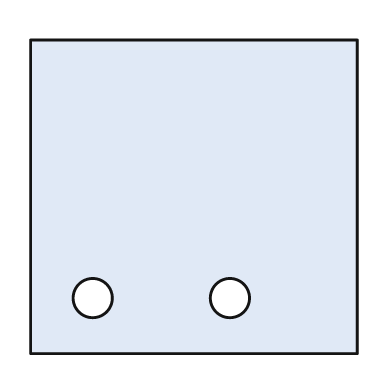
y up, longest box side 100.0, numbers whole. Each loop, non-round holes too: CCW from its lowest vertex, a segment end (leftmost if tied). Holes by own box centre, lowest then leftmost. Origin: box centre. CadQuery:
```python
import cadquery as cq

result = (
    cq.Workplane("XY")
    .moveTo(-50.0, -48.0)
    .lineTo(50.0, -48.0)
    .lineTo(50.0, 48.0)
    .lineTo(-50.0, 48.0)
    .close()
    .moveTo(-31.0, -31.0)
    .circle(6.0)
    .moveTo(11.0, -31.0)
    .circle(6.0)
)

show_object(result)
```